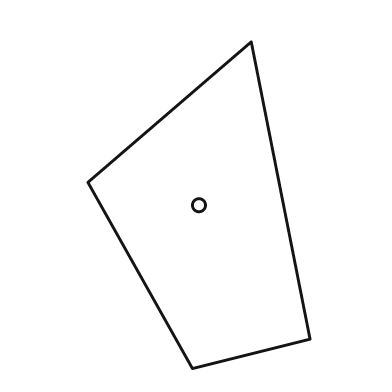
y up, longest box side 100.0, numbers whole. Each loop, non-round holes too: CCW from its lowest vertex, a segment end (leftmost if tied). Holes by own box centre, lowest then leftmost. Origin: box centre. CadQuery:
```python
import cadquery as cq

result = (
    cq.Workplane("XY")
    .moveTo(-2.0, -50.0)
    .lineTo(34.0, -41.0)
    .lineTo(16.0, 50.0)
    .lineTo(-34.0, 7.0)
    .close()
    .moveTo(0.0, 0.0)
    .circle(2.0)
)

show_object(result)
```